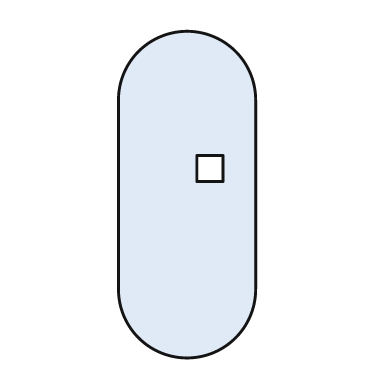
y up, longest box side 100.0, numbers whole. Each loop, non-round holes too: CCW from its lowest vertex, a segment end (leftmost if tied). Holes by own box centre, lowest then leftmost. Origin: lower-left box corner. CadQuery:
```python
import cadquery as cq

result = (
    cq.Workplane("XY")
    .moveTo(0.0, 21.0)
    .threePointArc((21.0, 0.0), (42.0, 21.0))
    .lineTo(42.0, 79.0)
    .threePointArc((21.0, 100.0), (0.0, 79.0))
    .close()
    .moveTo(24.0, 54.0)
    .lineTo(32.0, 54.0)
    .lineTo(32.0, 62.0)
    .lineTo(24.0, 62.0)
    .close()
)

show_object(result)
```